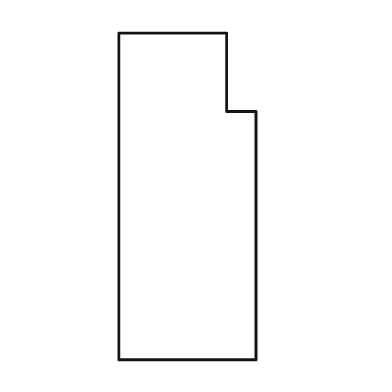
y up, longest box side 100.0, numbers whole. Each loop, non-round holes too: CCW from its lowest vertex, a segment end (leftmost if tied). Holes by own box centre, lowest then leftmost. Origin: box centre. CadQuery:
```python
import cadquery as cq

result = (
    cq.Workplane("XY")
    .moveTo(-21.0, -50.0)
    .lineTo(21.0, -50.0)
    .lineTo(21.0, 26.0)
    .lineTo(12.0, 26.0)
    .lineTo(12.0, 50.0)
    .lineTo(-21.0, 50.0)
    .close()
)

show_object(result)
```